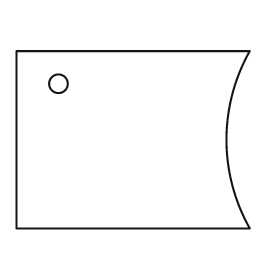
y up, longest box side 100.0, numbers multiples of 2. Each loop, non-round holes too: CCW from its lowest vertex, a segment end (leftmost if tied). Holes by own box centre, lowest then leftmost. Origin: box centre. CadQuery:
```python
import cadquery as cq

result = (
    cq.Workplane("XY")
    .moveTo(-50.0, -38.0)
    .lineTo(50.0, -38.0)
    .threePointArc((40.0, 0.0), (50.0, 38.0))
    .lineTo(-50.0, 38.0)
    .close()
    .moveTo(-32.0, 24.0)
    .circle(4.0)
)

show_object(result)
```